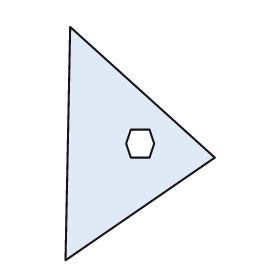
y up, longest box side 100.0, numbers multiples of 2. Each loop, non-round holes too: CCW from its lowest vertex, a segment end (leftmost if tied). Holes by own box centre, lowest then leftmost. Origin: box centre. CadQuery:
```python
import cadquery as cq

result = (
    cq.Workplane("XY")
    .moveTo(-32.0, -50.0)
    .lineTo(32.0, -6.0)
    .lineTo(-30.0, 50.0)
    .close()
    .moveTo(-4.0, -6.0)
    .lineTo(4.0, -6.0)
    .lineTo(6.0, 0.0)
    .lineTo(4.0, 6.0)
    .lineTo(-4.0, 6.0)
    .lineTo(-6.0, 0.0)
    .close()
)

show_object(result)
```